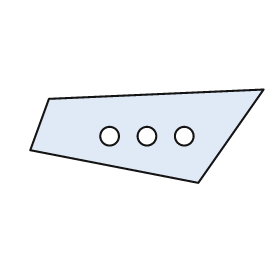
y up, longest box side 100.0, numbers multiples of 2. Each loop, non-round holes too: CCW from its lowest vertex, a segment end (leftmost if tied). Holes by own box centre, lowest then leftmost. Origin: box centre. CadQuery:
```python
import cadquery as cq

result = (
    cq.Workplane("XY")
    .moveTo(22.0, -20.0)
    .lineTo(50.0, 20.0)
    .lineTo(-42.0, 16.0)
    .lineTo(-50.0, -6.0)
    .close()
    .moveTo(-16.0, 0.0)
    .circle(4.0)
    .moveTo(0.0, 0.0)
    .circle(4.0)
    .moveTo(16.0, 0.0)
    .circle(4.0)
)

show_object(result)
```